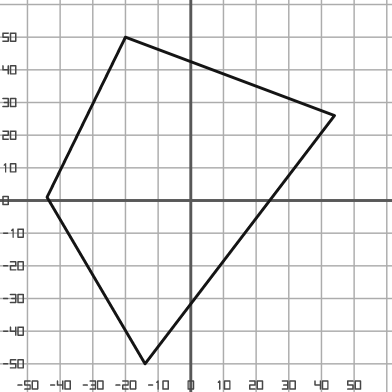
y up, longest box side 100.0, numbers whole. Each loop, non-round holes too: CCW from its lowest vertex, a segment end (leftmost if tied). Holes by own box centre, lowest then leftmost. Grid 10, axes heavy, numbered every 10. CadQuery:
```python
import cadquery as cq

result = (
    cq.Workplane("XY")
    .moveTo(-14.0, -50.0)
    .lineTo(44.0, 26.0)
    .lineTo(-20.0, 50.0)
    .lineTo(-44.0, 1.0)
    .close()
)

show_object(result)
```